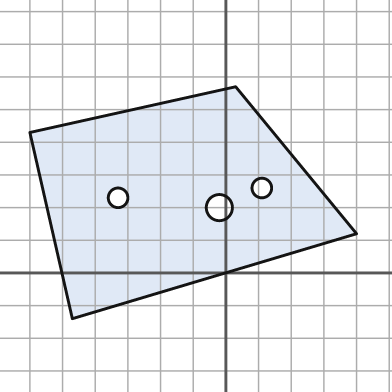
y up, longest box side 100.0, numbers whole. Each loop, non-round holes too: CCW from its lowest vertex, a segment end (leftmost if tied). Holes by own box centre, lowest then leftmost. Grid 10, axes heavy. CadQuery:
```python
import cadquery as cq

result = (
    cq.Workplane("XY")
    .moveTo(-47.0, -14.0)
    .lineTo(40.0, 12.0)
    .lineTo(3.0, 57.0)
    .lineTo(-60.0, 43.0)
    .close()
    .moveTo(-2.0, 20.0)
    .circle(4.0)
    .moveTo(-33.0, 23.0)
    .circle(3.0)
    .moveTo(11.0, 26.0)
    .circle(3.0)
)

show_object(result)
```